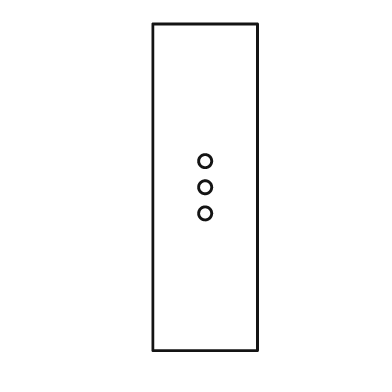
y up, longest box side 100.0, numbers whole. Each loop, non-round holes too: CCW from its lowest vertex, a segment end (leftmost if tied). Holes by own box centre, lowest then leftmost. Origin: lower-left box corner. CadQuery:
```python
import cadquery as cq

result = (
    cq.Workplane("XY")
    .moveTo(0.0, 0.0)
    .lineTo(32.0, 0.0)
    .lineTo(32.0, 100.0)
    .lineTo(0.0, 100.0)
    .close()
    .moveTo(16.0, 42.0)
    .circle(2.0)
    .moveTo(16.0, 50.0)
    .circle(2.0)
    .moveTo(16.0, 58.0)
    .circle(2.0)
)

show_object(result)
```